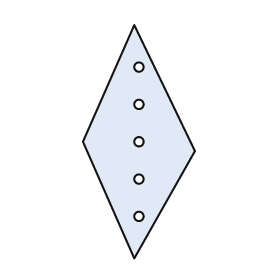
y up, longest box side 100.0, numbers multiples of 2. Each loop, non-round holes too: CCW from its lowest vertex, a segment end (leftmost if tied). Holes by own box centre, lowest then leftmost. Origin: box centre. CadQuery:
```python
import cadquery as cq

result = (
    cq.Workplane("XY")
    .moveTo(-2.0, -50.0)
    .lineTo(24.0, -4.0)
    .lineTo(-2.0, 50.0)
    .lineTo(-24.0, 0.0)
    .close()
    .moveTo(0.0, -32.0)
    .circle(2.0)
    .moveTo(0.0, -16.0)
    .circle(2.0)
    .moveTo(0.0, 0.0)
    .circle(2.0)
    .moveTo(0.0, 16.0)
    .circle(2.0)
    .moveTo(0.0, 32.0)
    .circle(2.0)
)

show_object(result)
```